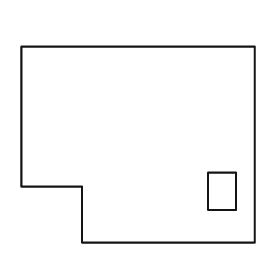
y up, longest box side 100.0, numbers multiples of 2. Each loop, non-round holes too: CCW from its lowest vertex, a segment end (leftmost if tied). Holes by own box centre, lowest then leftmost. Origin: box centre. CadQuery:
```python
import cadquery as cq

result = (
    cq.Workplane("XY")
    .moveTo(-24.0, -42.0)
    .lineTo(50.0, -42.0)
    .lineTo(50.0, 42.0)
    .lineTo(-50.0, 42.0)
    .lineTo(-50.0, -18.0)
    .lineTo(-24.0, -18.0)
    .close()
    .moveTo(30.0, -28.0)
    .lineTo(42.0, -28.0)
    .lineTo(42.0, -12.0)
    .lineTo(30.0, -12.0)
    .close()
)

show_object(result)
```